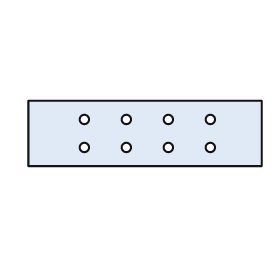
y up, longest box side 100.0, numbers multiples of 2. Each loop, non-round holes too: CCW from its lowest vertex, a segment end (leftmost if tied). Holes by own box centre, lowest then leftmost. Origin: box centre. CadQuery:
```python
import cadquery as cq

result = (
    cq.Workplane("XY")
    .moveTo(-50.0, -14.0)
    .lineTo(50.0, -14.0)
    .lineTo(50.0, 14.0)
    .lineTo(-50.0, 14.0)
    .close()
    .moveTo(-26.0, -6.0)
    .circle(2.0)
    .moveTo(-8.0, -6.0)
    .circle(2.0)
    .moveTo(10.0, -6.0)
    .circle(2.0)
    .moveTo(28.0, -6.0)
    .circle(2.0)
    .moveTo(-26.0, 6.0)
    .circle(2.0)
    .moveTo(-8.0, 6.0)
    .circle(2.0)
    .moveTo(10.0, 6.0)
    .circle(2.0)
    .moveTo(28.0, 6.0)
    .circle(2.0)
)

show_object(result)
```